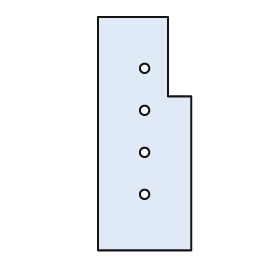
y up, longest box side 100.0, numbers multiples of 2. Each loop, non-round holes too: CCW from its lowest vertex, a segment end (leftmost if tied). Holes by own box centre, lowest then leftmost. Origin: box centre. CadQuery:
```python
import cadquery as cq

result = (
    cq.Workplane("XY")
    .moveTo(-20.0, -50.0)
    .lineTo(20.0, -50.0)
    .lineTo(20.0, 16.0)
    .lineTo(10.0, 16.0)
    .lineTo(10.0, 50.0)
    .lineTo(-20.0, 50.0)
    .close()
    .moveTo(0.0, -26.0)
    .circle(2.0)
    .moveTo(0.0, -8.0)
    .circle(2.0)
    .moveTo(0.0, 10.0)
    .circle(2.0)
    .moveTo(0.0, 28.0)
    .circle(2.0)
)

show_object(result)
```